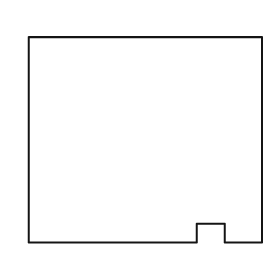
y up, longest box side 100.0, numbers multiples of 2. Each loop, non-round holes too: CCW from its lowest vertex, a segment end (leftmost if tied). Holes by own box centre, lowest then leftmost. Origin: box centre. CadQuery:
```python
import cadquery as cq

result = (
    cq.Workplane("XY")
    .moveTo(-50.0, -44.0)
    .lineTo(22.0, -44.0)
    .lineTo(22.0, -36.0)
    .lineTo(34.0, -36.0)
    .lineTo(34.0, -44.0)
    .lineTo(50.0, -44.0)
    .lineTo(50.0, 44.0)
    .lineTo(-50.0, 44.0)
    .close()
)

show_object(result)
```